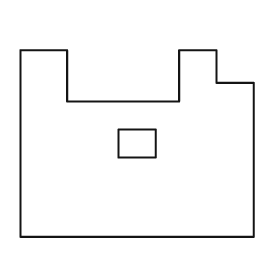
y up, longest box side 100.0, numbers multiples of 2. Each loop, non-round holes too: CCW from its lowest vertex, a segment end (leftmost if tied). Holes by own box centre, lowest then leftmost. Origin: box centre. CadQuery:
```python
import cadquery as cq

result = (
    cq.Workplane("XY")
    .moveTo(-50.0, -40.0)
    .lineTo(50.0, -40.0)
    .lineTo(50.0, 26.0)
    .lineTo(34.0, 26.0)
    .lineTo(34.0, 40.0)
    .lineTo(18.0, 40.0)
    .lineTo(18.0, 18.0)
    .lineTo(-30.0, 18.0)
    .lineTo(-30.0, 40.0)
    .lineTo(-50.0, 40.0)
    .close()
    .moveTo(-8.0, -6.0)
    .lineTo(8.0, -6.0)
    .lineTo(8.0, 6.0)
    .lineTo(-8.0, 6.0)
    .close()
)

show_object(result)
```